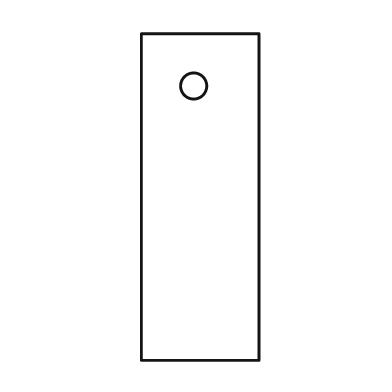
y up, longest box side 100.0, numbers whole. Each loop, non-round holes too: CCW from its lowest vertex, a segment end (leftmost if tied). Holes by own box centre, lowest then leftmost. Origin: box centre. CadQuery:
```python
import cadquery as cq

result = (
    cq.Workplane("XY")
    .moveTo(-18.0, -50.0)
    .lineTo(18.0, -50.0)
    .lineTo(18.0, 50.0)
    .lineTo(-18.0, 50.0)
    .close()
    .moveTo(-2.0, 34.0)
    .circle(4.0)
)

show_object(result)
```